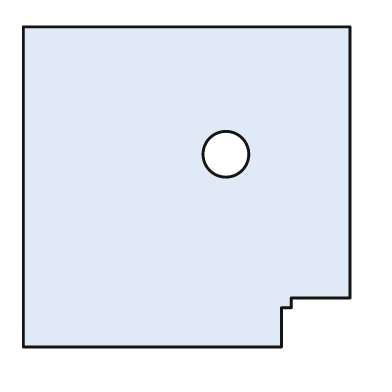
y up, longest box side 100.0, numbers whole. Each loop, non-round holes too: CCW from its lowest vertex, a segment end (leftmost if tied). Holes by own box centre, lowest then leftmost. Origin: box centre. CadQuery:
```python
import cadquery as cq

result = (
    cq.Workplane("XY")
    .moveTo(-50.0, -49.0)
    .lineTo(29.0, -49.0)
    .lineTo(29.0, -37.0)
    .lineTo(32.0, -37.0)
    .lineTo(32.0, -34.0)
    .lineTo(50.0, -34.0)
    .lineTo(50.0, 49.0)
    .lineTo(-50.0, 49.0)
    .close()
    .moveTo(12.0, 10.0)
    .circle(7.0)
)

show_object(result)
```